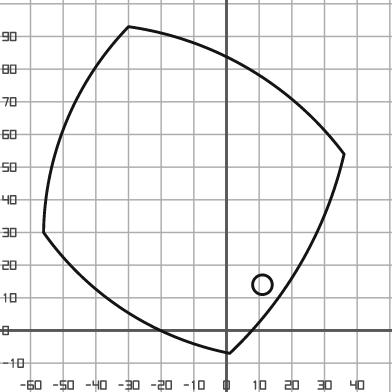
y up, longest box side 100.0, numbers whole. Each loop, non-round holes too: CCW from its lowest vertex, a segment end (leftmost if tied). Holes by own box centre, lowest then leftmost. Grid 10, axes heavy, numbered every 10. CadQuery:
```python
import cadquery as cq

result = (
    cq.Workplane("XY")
    .moveTo(1.0, -7.0)
    .threePointArc((23.0, 21.0), (36.0, 54.0))
    .threePointArc((7.0, 80.0), (-30.0, 93.0))
    .threePointArc((-49.0, 64.0), (-56.0, 30.0))
    .threePointArc((-31.0, 6.0), (1.0, -7.0))
    .close()
    .moveTo(11.0, 14.0)
    .circle(3.0)
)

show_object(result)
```